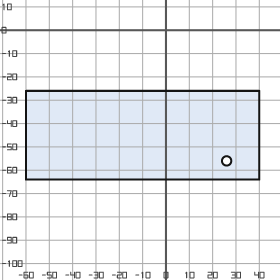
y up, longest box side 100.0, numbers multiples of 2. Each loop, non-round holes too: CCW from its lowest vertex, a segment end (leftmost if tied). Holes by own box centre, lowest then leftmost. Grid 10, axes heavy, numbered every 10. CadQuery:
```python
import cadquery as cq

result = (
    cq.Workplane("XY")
    .moveTo(-60.0, -64.0)
    .lineTo(40.0, -64.0)
    .lineTo(40.0, -26.0)
    .lineTo(-60.0, -26.0)
    .close()
    .moveTo(26.0, -56.0)
    .circle(2.0)
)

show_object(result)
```